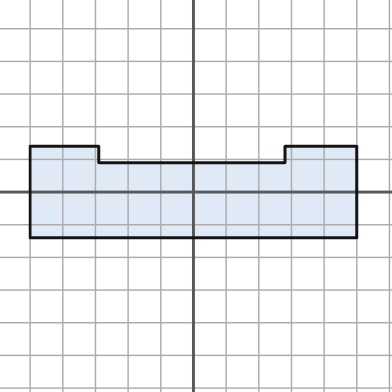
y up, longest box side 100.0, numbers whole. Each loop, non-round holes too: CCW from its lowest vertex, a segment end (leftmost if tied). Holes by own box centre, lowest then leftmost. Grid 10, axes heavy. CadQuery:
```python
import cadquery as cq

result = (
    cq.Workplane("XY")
    .moveTo(-50.0, -14.0)
    .lineTo(50.0, -14.0)
    .lineTo(50.0, 14.0)
    .lineTo(28.0, 14.0)
    .lineTo(28.0, 9.0)
    .lineTo(-29.0, 9.0)
    .lineTo(-29.0, 14.0)
    .lineTo(-50.0, 14.0)
    .close()
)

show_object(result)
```